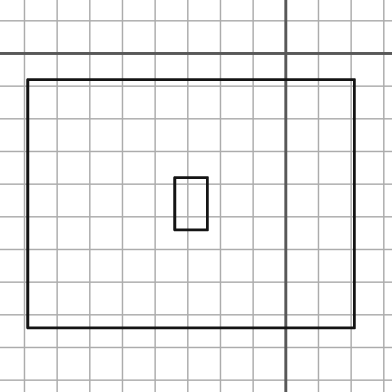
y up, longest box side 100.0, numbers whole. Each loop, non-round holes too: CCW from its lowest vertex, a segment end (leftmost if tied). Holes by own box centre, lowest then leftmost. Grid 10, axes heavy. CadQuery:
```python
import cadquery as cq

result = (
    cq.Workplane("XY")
    .moveTo(-79.0, -84.0)
    .lineTo(21.0, -84.0)
    .lineTo(21.0, -8.0)
    .lineTo(-79.0, -8.0)
    .close()
    .moveTo(-34.0, -54.0)
    .lineTo(-24.0, -54.0)
    .lineTo(-24.0, -38.0)
    .lineTo(-34.0, -38.0)
    .close()
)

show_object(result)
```